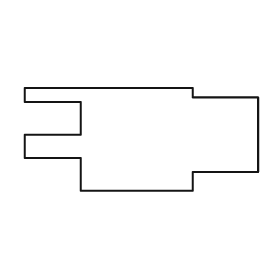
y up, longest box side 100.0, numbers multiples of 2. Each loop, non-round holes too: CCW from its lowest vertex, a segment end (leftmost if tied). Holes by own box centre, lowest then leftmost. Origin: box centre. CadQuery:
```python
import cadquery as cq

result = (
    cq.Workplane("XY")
    .moveTo(-26.0, -22.0)
    .lineTo(22.0, -22.0)
    .lineTo(22.0, -14.0)
    .lineTo(50.0, -14.0)
    .lineTo(50.0, 18.0)
    .lineTo(22.0, 18.0)
    .lineTo(22.0, 22.0)
    .lineTo(-50.0, 22.0)
    .lineTo(-50.0, 16.0)
    .lineTo(-26.0, 16.0)
    .lineTo(-26.0, 2.0)
    .lineTo(-50.0, 2.0)
    .lineTo(-50.0, -8.0)
    .lineTo(-26.0, -8.0)
    .close()
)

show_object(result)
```